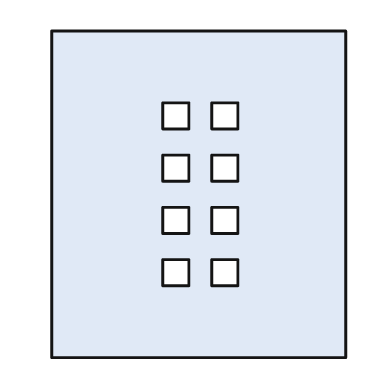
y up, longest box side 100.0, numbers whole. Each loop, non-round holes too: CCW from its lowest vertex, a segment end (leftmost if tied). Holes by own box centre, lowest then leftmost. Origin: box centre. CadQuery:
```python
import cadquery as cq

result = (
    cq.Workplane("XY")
    .moveTo(-45.0, -50.0)
    .lineTo(45.0, -50.0)
    .lineTo(45.0, 50.0)
    .lineTo(-45.0, 50.0)
    .close()
    .moveTo(-11.0, -28.0)
    .lineTo(-3.0, -28.0)
    .lineTo(-3.0, -20.0)
    .lineTo(-11.0, -20.0)
    .close()
    .moveTo(4.0, -28.0)
    .lineTo(12.0, -28.0)
    .lineTo(12.0, -20.0)
    .lineTo(4.0, -20.0)
    .close()
    .moveTo(-11.0, -12.0)
    .lineTo(-3.0, -12.0)
    .lineTo(-3.0, -4.0)
    .lineTo(-11.0, -4.0)
    .close()
    .moveTo(4.0, -12.0)
    .lineTo(12.0, -12.0)
    .lineTo(12.0, -4.0)
    .lineTo(4.0, -4.0)
    .close()
    .moveTo(-11.0, 4.0)
    .lineTo(-3.0, 4.0)
    .lineTo(-3.0, 12.0)
    .lineTo(-11.0, 12.0)
    .close()
    .moveTo(4.0, 4.0)
    .lineTo(12.0, 4.0)
    .lineTo(12.0, 12.0)
    .lineTo(4.0, 12.0)
    .close()
    .moveTo(-11.0, 20.0)
    .lineTo(-3.0, 20.0)
    .lineTo(-3.0, 28.0)
    .lineTo(-11.0, 28.0)
    .close()
    .moveTo(4.0, 20.0)
    .lineTo(12.0, 20.0)
    .lineTo(12.0, 28.0)
    .lineTo(4.0, 28.0)
    .close()
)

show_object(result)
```